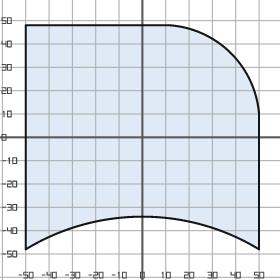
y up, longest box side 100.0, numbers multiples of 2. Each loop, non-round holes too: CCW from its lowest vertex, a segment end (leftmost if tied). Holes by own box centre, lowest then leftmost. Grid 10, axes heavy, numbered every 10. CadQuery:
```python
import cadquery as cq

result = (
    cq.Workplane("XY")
    .moveTo(-50.0, -48.0)
    .threePointArc((0.0, -34.0), (50.0, -48.0))
    .lineTo(50.0, 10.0)
    .threePointArc((38.0, 36.0), (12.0, 48.0))
    .lineTo(-50.0, 48.0)
    .close()
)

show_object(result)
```